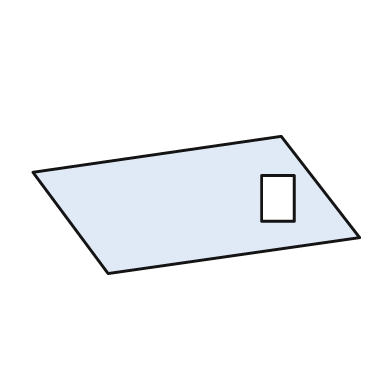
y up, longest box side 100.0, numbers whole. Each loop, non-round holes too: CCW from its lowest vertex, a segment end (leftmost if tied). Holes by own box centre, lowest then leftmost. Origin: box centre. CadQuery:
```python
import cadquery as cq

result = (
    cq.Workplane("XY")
    .moveTo(-27.0, -21.0)
    .lineTo(50.0, -10.0)
    .lineTo(26.0, 21.0)
    .lineTo(-50.0, 10.0)
    .close()
    .moveTo(20.0, -5.0)
    .lineTo(30.0, -5.0)
    .lineTo(30.0, 9.0)
    .lineTo(20.0, 9.0)
    .close()
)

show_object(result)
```